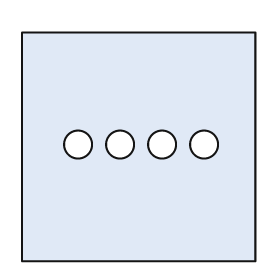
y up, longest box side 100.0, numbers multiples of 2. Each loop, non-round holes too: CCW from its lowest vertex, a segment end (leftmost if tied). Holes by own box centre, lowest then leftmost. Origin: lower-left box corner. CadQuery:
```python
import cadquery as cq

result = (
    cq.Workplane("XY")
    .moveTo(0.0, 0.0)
    .lineTo(100.0, 0.0)
    .lineTo(100.0, 98.0)
    .lineTo(0.0, 98.0)
    .close()
    .moveTo(24.0, 50.0)
    .circle(6.0)
    .moveTo(42.0, 50.0)
    .circle(6.0)
    .moveTo(60.0, 50.0)
    .circle(6.0)
    .moveTo(78.0, 50.0)
    .circle(6.0)
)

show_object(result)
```